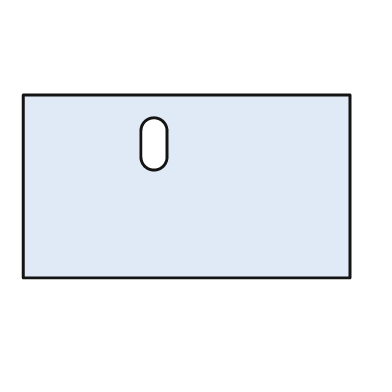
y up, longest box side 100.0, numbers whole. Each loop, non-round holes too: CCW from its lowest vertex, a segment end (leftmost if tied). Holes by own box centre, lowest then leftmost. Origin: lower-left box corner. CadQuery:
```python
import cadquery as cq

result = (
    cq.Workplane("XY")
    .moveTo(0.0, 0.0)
    .lineTo(100.0, 0.0)
    .lineTo(100.0, 56.0)
    .lineTo(0.0, 56.0)
    .close()
    .moveTo(36.0, 37.0)
    .threePointArc((40.0, 33.0), (44.0, 37.0))
    .lineTo(44.0, 45.0)
    .threePointArc((40.0, 49.0), (36.0, 45.0))
    .close()
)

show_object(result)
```